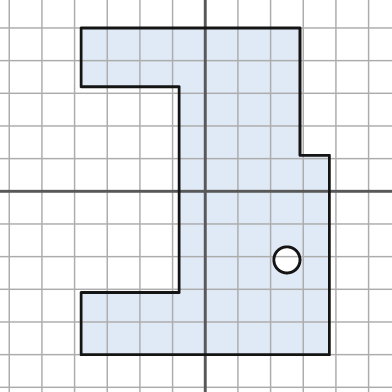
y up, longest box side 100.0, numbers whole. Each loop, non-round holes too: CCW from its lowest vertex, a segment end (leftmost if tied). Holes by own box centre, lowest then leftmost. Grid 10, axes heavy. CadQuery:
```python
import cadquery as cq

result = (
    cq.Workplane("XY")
    .moveTo(-38.0, -50.0)
    .lineTo(38.0, -50.0)
    .lineTo(38.0, 11.0)
    .lineTo(29.0, 11.0)
    .lineTo(29.0, 50.0)
    .lineTo(-38.0, 50.0)
    .lineTo(-38.0, 32.0)
    .lineTo(-8.0, 32.0)
    .lineTo(-8.0, -31.0)
    .lineTo(-38.0, -31.0)
    .close()
    .moveTo(25.0, -21.0)
    .circle(4.0)
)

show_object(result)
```